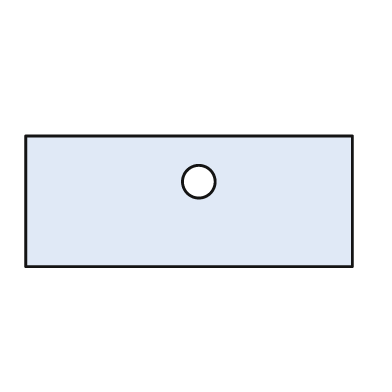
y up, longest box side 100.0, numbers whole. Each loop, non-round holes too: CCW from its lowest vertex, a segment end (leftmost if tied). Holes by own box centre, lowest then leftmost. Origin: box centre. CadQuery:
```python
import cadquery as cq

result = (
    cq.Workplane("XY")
    .moveTo(-50.0, -20.0)
    .lineTo(50.0, -20.0)
    .lineTo(50.0, 20.0)
    .lineTo(-50.0, 20.0)
    .close()
    .moveTo(3.0, 6.0)
    .circle(5.0)
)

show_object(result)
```